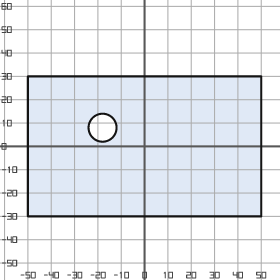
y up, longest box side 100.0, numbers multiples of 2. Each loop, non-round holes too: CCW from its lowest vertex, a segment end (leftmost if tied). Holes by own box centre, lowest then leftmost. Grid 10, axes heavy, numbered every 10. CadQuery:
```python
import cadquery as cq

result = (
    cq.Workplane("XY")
    .moveTo(-50.0, -30.0)
    .lineTo(50.0, -30.0)
    .lineTo(50.0, 30.0)
    .lineTo(-50.0, 30.0)
    .close()
    .moveTo(-18.0, 8.0)
    .circle(6.0)
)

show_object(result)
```